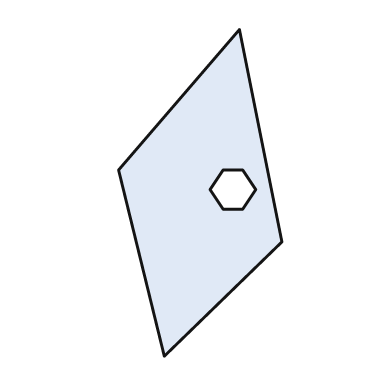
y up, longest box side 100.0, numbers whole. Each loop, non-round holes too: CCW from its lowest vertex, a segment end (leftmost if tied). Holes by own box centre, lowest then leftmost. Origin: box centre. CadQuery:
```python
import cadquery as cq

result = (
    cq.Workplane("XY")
    .moveTo(-11.0, -50.0)
    .lineTo(25.0, -15.0)
    .lineTo(12.0, 50.0)
    .lineTo(-25.0, 7.0)
    .close()
    .moveTo(7.0, -5.0)
    .lineTo(13.0, -5.0)
    .lineTo(17.0, 1.0)
    .lineTo(13.0, 7.0)
    .lineTo(7.0, 7.0)
    .lineTo(3.0, 1.0)
    .close()
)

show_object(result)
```